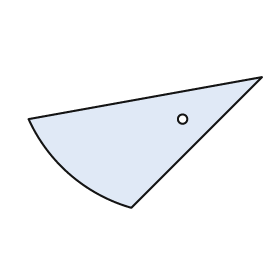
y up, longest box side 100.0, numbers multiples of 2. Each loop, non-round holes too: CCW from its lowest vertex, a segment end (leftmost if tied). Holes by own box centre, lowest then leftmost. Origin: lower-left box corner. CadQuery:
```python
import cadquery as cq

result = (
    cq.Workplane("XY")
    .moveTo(44.0, 0.0)
    .lineTo(100.0, 56.0)
    .lineTo(0.0, 38.0)
    .threePointArc((18.0, 14.0), (44.0, 0.0))
    .close()
    .moveTo(66.0, 38.0)
    .circle(2.0)
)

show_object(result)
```